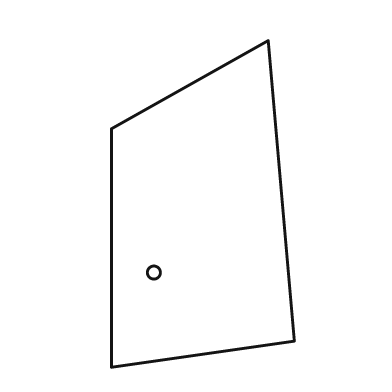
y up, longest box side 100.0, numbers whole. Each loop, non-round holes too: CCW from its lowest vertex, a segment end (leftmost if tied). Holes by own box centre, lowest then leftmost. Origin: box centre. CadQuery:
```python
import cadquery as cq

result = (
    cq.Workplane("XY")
    .moveTo(-28.0, -50.0)
    .lineTo(28.0, -42.0)
    .lineTo(20.0, 50.0)
    .lineTo(-28.0, 23.0)
    .close()
    .moveTo(-15.0, -21.0)
    .circle(2.0)
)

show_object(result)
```